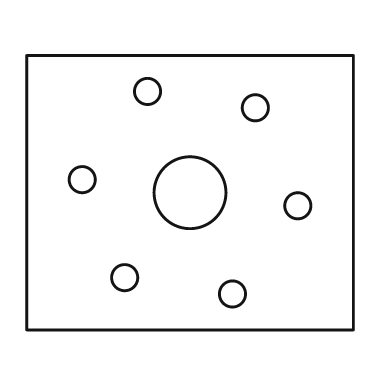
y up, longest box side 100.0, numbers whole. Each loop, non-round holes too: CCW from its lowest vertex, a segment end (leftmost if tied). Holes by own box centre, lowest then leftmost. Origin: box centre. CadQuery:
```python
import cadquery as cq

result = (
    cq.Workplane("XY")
    .moveTo(-50.0, -42.0)
    .lineTo(50.0, -42.0)
    .lineTo(50.0, 42.0)
    .lineTo(-50.0, 42.0)
    .close()
    .moveTo(13.0, -31.0)
    .circle(4.0)
    .moveTo(-20.0, -26.0)
    .circle(4.0)
    .moveTo(33.0, -4.0)
    .circle(4.0)
    .moveTo(0.0, 0.0)
    .circle(11.0)
    .moveTo(-33.0, 4.0)
    .circle(4.0)
    .moveTo(20.0, 26.0)
    .circle(4.0)
    .moveTo(-13.0, 31.0)
    .circle(4.0)
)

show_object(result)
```